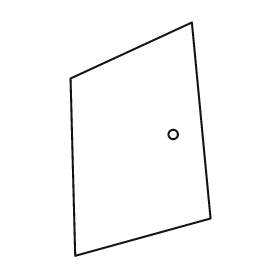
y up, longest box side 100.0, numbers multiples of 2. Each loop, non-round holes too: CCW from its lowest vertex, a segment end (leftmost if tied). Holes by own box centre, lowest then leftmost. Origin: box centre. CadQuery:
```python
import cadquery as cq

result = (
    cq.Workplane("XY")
    .moveTo(-28.0, -50.0)
    .lineTo(30.0, -34.0)
    .lineTo(22.0, 50.0)
    .lineTo(-30.0, 26.0)
    .close()
    .moveTo(14.0, 2.0)
    .circle(2.0)
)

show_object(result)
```